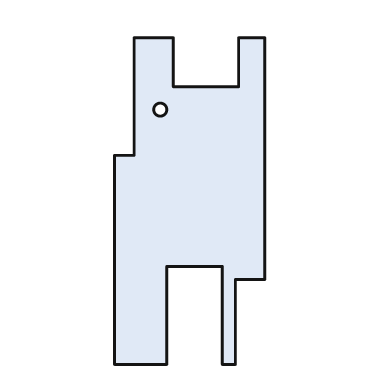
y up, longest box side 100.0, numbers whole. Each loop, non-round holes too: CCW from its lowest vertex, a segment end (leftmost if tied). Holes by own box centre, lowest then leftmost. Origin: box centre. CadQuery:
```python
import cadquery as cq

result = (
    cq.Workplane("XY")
    .moveTo(-23.0, -50.0)
    .lineTo(-7.0, -50.0)
    .lineTo(-7.0, -20.0)
    .lineTo(10.0, -20.0)
    .lineTo(10.0, -50.0)
    .lineTo(14.0, -50.0)
    .lineTo(14.0, -24.0)
    .lineTo(23.0, -24.0)
    .lineTo(23.0, 50.0)
    .lineTo(15.0, 50.0)
    .lineTo(15.0, 35.0)
    .lineTo(-5.0, 35.0)
    .lineTo(-5.0, 50.0)
    .lineTo(-17.0, 50.0)
    .lineTo(-17.0, 14.0)
    .lineTo(-23.0, 14.0)
    .close()
    .moveTo(-9.0, 28.0)
    .circle(2.0)
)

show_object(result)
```